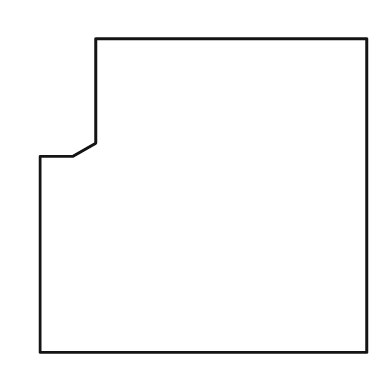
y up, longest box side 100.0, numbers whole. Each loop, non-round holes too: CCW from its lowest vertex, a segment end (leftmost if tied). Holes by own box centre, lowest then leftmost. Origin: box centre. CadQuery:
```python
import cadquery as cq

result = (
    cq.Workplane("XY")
    .moveTo(-50.0, -48.0)
    .lineTo(50.0, -48.0)
    .lineTo(50.0, 48.0)
    .lineTo(-33.0, 48.0)
    .lineTo(-33.0, 16.0)
    .lineTo(-40.0, 12.0)
    .lineTo(-50.0, 12.0)
    .close()
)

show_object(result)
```